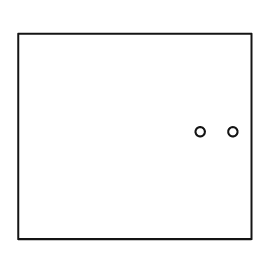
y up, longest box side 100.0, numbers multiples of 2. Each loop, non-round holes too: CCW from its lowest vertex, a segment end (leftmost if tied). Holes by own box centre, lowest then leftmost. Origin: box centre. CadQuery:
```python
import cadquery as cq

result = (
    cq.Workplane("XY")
    .moveTo(-50.0, -44.0)
    .lineTo(50.0, -44.0)
    .lineTo(50.0, 44.0)
    .lineTo(-50.0, 44.0)
    .close()
    .moveTo(28.0, 2.0)
    .circle(2.0)
    .moveTo(42.0, 2.0)
    .circle(2.0)
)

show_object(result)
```